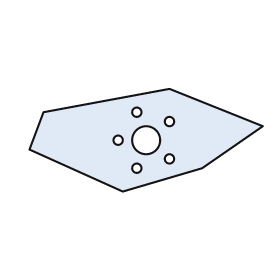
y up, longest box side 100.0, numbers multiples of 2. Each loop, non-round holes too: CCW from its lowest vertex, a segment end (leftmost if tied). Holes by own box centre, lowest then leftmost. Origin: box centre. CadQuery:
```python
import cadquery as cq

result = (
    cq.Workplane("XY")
    .moveTo(-10.0, -22.0)
    .lineTo(24.0, -12.0)
    .lineTo(50.0, 6.0)
    .lineTo(10.0, 22.0)
    .lineTo(-44.0, 12.0)
    .lineTo(-50.0, -4.0)
    .close()
    .moveTo(-4.0, -12.0)
    .circle(2.0)
    .moveTo(10.0, -8.0)
    .circle(2.0)
    .moveTo(-12.0, 0.0)
    .circle(2.0)
    .moveTo(0.0, 0.0)
    .circle(6.0)
    .moveTo(10.0, 8.0)
    .circle(2.0)
    .moveTo(-4.0, 12.0)
    .circle(2.0)
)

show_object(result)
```